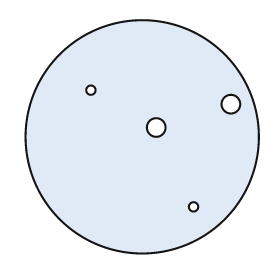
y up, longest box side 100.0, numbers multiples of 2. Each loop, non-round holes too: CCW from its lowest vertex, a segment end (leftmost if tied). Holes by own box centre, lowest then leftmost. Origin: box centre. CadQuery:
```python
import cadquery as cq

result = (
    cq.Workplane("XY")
    .moveTo(0.0, 0.0)
    .circle(50.0)
    .moveTo(22.0, -30.0)
    .circle(2.0)
    .moveTo(6.0, 4.0)
    .circle(4.0)
    .moveTo(38.0, 14.0)
    .circle(4.0)
    .moveTo(-22.0, 20.0)
    .circle(2.0)
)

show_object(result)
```